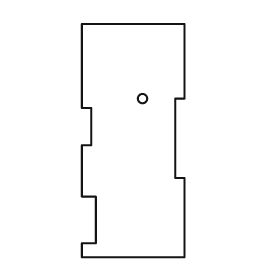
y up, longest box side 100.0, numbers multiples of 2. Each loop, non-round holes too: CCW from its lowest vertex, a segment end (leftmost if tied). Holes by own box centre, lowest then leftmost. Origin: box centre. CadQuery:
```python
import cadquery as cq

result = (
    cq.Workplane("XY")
    .moveTo(-22.0, -50.0)
    .lineTo(22.0, -50.0)
    .lineTo(22.0, -16.0)
    .lineTo(18.0, -16.0)
    .lineTo(18.0, 18.0)
    .lineTo(22.0, 18.0)
    .lineTo(22.0, 50.0)
    .lineTo(-22.0, 50.0)
    .lineTo(-22.0, 14.0)
    .lineTo(-18.0, 14.0)
    .lineTo(-18.0, -2.0)
    .lineTo(-22.0, -2.0)
    .lineTo(-22.0, -24.0)
    .lineTo(-16.0, -24.0)
    .lineTo(-16.0, -44.0)
    .lineTo(-22.0, -44.0)
    .close()
    .moveTo(4.0, 18.0)
    .circle(2.0)
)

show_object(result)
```